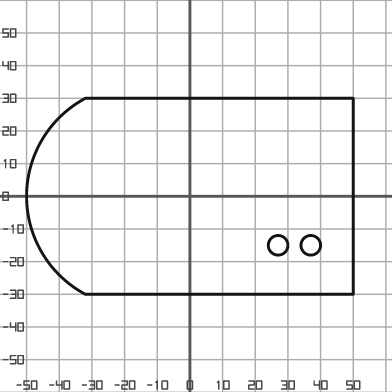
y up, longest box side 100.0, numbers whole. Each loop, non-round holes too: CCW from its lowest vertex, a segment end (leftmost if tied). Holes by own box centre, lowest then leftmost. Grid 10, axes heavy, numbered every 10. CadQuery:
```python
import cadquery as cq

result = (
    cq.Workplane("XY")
    .moveTo(-32.0, -30.0)
    .lineTo(50.0, -30.0)
    .lineTo(50.0, 30.0)
    .lineTo(-32.0, 30.0)
    .threePointArc((-50.0, 0.0), (-32.0, -30.0))
    .close()
    .moveTo(27.0, -15.0)
    .circle(3.0)
    .moveTo(37.0, -15.0)
    .circle(3.0)
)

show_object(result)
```